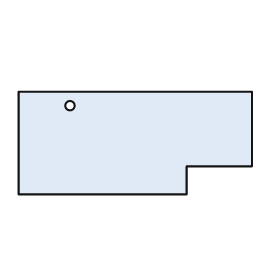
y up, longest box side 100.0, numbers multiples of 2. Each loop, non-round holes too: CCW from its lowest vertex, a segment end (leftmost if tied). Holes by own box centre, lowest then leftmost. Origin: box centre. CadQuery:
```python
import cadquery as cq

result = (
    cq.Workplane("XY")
    .moveTo(-50.0, -22.0)
    .lineTo(22.0, -22.0)
    .lineTo(22.0, -10.0)
    .lineTo(50.0, -10.0)
    .lineTo(50.0, 22.0)
    .lineTo(-50.0, 22.0)
    .close()
    .moveTo(-28.0, 16.0)
    .circle(2.0)
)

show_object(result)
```